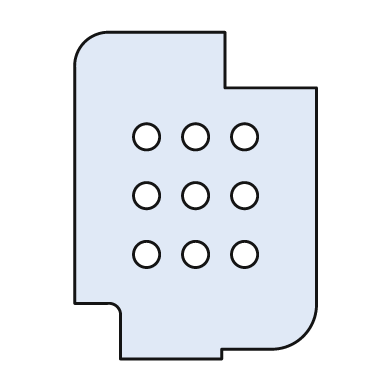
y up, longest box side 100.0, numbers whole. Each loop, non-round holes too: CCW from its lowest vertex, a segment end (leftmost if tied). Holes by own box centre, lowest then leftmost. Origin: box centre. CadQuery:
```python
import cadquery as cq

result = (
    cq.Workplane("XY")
    .moveTo(-23.0, -50.0)
    .lineTo(8.0, -50.0)
    .lineTo(8.0, -47.0)
    .lineTo(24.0, -47.0)
    .threePointArc((33.0, -43.0), (37.0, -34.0))
    .lineTo(37.0, 33.0)
    .lineTo(9.0, 33.0)
    .lineTo(9.0, 50.0)
    .lineTo(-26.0, 50.0)
    .threePointArc((-34.0, 47.0), (-37.0, 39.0))
    .lineTo(-37.0, -33.0)
    .lineTo(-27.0, -33.0)
    .threePointArc((-24.0, -34.0), (-23.0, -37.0))
    .close()
    .moveTo(-15.0, -18.0)
    .circle(4.0)
    .moveTo(0.0, -18.0)
    .circle(4.0)
    .moveTo(15.0, -18.0)
    .circle(4.0)
    .moveTo(-15.0, 0.0)
    .circle(4.0)
    .moveTo(0.0, 0.0)
    .circle(4.0)
    .moveTo(15.0, 0.0)
    .circle(4.0)
    .moveTo(-15.0, 18.0)
    .circle(4.0)
    .moveTo(0.0, 18.0)
    .circle(4.0)
    .moveTo(15.0, 18.0)
    .circle(4.0)
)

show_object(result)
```